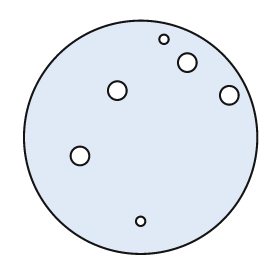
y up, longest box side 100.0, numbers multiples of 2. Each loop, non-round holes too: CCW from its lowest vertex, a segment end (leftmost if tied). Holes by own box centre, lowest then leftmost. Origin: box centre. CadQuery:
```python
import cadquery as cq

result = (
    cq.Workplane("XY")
    .moveTo(0.0, 0.0)
    .circle(50.0)
    .moveTo(0.0, -36.0)
    .circle(2.0)
    .moveTo(-26.0, -8.0)
    .circle(4.0)
    .moveTo(38.0, 18.0)
    .circle(4.0)
    .moveTo(-10.0, 20.0)
    .circle(4.0)
    .moveTo(20.0, 32.0)
    .circle(4.0)
    .moveTo(10.0, 42.0)
    .circle(2.0)
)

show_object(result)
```